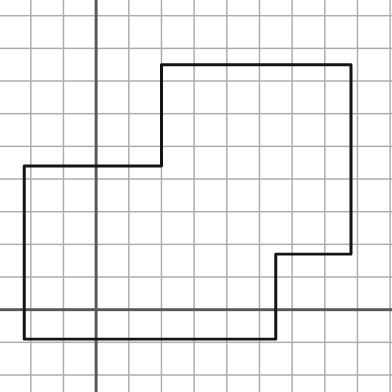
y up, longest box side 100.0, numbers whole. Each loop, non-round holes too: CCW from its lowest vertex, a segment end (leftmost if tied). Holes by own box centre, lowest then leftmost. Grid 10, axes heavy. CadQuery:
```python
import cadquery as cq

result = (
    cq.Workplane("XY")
    .moveTo(-22.0, -9.0)
    .lineTo(55.0, -9.0)
    .lineTo(55.0, 17.0)
    .lineTo(78.0, 17.0)
    .lineTo(78.0, 75.0)
    .lineTo(20.0, 75.0)
    .lineTo(20.0, 44.0)
    .lineTo(-22.0, 44.0)
    .close()
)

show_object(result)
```